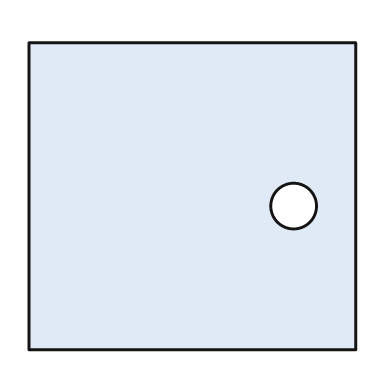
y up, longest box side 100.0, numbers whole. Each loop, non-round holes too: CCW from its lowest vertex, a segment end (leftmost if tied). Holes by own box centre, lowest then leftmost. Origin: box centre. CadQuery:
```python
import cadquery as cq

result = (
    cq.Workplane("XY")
    .moveTo(-50.0, -47.0)
    .lineTo(50.0, -47.0)
    .lineTo(50.0, 47.0)
    .lineTo(-50.0, 47.0)
    .close()
    .moveTo(31.0, -3.0)
    .circle(7.0)
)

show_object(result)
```